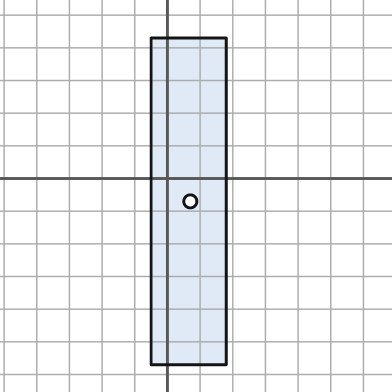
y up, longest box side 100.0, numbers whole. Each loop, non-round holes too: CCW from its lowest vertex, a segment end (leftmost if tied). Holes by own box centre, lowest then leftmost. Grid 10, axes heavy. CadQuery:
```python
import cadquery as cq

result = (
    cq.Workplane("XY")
    .moveTo(-5.0, -57.0)
    .lineTo(18.0, -57.0)
    .lineTo(18.0, 43.0)
    .lineTo(-5.0, 43.0)
    .close()
    .moveTo(7.0, -7.0)
    .circle(2.0)
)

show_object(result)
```